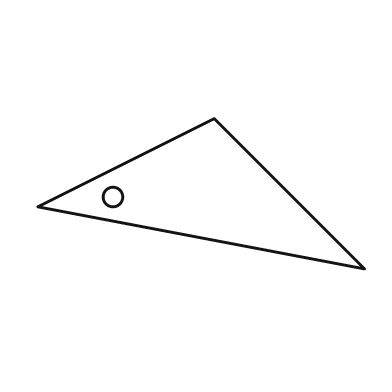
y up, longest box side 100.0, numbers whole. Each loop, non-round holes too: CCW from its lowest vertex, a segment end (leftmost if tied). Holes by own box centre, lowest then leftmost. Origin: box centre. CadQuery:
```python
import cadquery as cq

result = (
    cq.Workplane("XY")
    .moveTo(50.0, -23.0)
    .lineTo(4.0, 23.0)
    .lineTo(-50.0, -4.0)
    .close()
    .moveTo(-27.0, -1.0)
    .circle(3.0)
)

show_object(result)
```